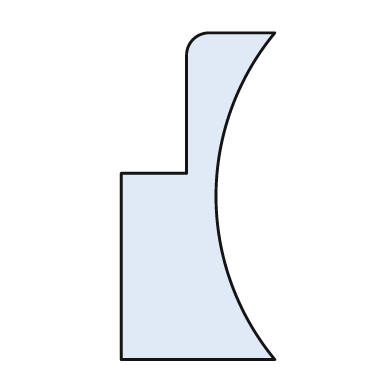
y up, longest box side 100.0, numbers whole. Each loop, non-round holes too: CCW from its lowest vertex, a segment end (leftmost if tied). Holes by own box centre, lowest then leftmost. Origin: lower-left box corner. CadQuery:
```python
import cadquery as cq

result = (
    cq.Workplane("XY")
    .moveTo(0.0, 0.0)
    .lineTo(47.0, 0.0)
    .threePointArc((29.0, 50.0), (47.0, 100.0))
    .lineTo(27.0, 100.0)
    .threePointArc((22.0, 98.0), (20.0, 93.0))
    .lineTo(20.0, 57.0)
    .lineTo(0.0, 57.0)
    .close()
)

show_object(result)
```